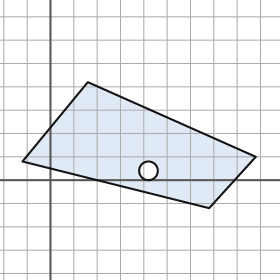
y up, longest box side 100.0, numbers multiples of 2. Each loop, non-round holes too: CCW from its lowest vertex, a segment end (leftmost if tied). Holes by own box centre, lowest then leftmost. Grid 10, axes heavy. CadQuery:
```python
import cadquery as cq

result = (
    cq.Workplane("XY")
    .moveTo(68.0, -12.0)
    .lineTo(88.0, 10.0)
    .lineTo(16.0, 42.0)
    .lineTo(-12.0, 8.0)
    .close()
    .moveTo(42.0, 4.0)
    .circle(4.0)
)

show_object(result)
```